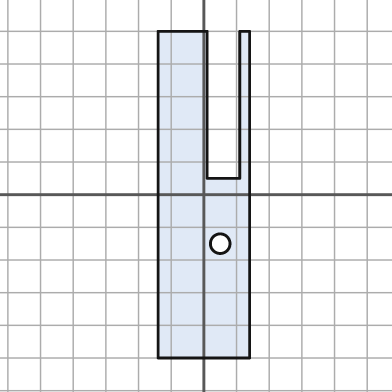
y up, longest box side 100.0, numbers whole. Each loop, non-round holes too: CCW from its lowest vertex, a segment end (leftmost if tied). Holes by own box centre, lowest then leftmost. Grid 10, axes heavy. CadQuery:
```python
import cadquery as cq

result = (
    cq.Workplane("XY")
    .moveTo(-14.0, -50.0)
    .lineTo(14.0, -50.0)
    .lineTo(14.0, 50.0)
    .lineTo(11.0, 50.0)
    .lineTo(11.0, 5.0)
    .lineTo(1.0, 5.0)
    .lineTo(1.0, 50.0)
    .lineTo(-14.0, 50.0)
    .close()
    .moveTo(5.0, -15.0)
    .circle(3.0)
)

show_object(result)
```